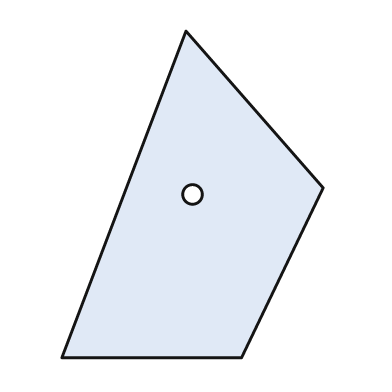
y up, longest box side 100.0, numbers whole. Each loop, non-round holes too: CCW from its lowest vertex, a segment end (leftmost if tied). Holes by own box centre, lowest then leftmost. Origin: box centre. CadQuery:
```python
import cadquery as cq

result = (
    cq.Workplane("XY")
    .moveTo(-40.0, -50.0)
    .lineTo(15.0, -50.0)
    .lineTo(40.0, 2.0)
    .lineTo(-2.0, 50.0)
    .close()
    .moveTo(0.0, 0.0)
    .circle(3.0)
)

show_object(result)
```